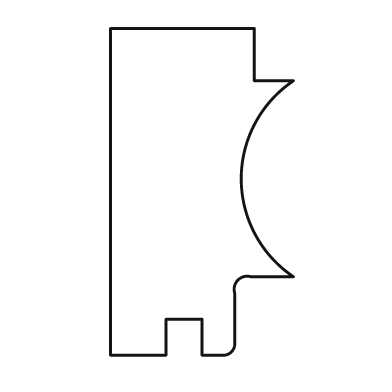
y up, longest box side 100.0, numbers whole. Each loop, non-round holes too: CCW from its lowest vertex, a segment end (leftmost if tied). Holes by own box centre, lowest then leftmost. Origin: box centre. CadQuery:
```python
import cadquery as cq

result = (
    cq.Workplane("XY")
    .moveTo(-28.0, -50.0)
    .lineTo(-11.0, -50.0)
    .lineTo(-11.0, -39.0)
    .lineTo(0.0, -39.0)
    .lineTo(0.0, -50.0)
    .lineTo(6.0, -50.0)
    .threePointArc((9.0, -49.0), (10.0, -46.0))
    .lineTo(10.0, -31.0)
    .threePointArc((11.0, -27.0), (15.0, -26.0))
    .lineTo(28.0, -26.0)
    .threePointArc((12.0, 4.0), (28.0, 34.0))
    .lineTo(16.0, 34.0)
    .lineTo(16.0, 50.0)
    .lineTo(-28.0, 50.0)
    .close()
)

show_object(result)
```